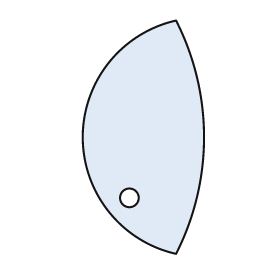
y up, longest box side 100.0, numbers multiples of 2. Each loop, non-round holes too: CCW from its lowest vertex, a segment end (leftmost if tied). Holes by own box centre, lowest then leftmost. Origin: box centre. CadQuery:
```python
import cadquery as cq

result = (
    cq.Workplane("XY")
    .moveTo(14.0, -50.0)
    .threePointArc((26.0, 0.0), (14.0, 50.0))
    .threePointArc((-26.0, 0.0), (14.0, -50.0))
    .close()
    .moveTo(-6.0, -26.0)
    .circle(4.0)
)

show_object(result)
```